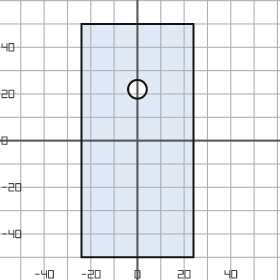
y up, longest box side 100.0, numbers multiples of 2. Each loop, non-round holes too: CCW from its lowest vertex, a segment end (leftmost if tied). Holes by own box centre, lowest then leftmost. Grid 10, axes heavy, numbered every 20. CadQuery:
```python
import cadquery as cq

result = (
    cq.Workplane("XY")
    .moveTo(-24.0, -50.0)
    .lineTo(24.0, -50.0)
    .lineTo(24.0, 50.0)
    .lineTo(-24.0, 50.0)
    .close()
    .moveTo(0.0, 22.0)
    .circle(4.0)
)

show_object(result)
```